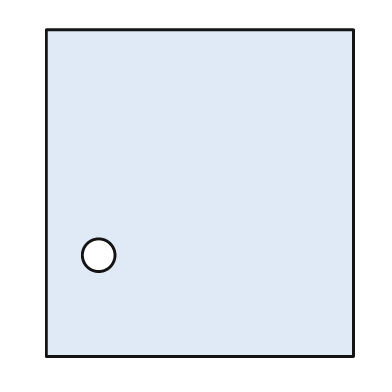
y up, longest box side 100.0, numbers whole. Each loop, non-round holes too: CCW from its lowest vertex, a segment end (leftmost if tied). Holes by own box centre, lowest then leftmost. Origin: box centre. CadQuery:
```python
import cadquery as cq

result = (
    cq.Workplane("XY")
    .moveTo(-47.0, -50.0)
    .lineTo(47.0, -50.0)
    .lineTo(47.0, 50.0)
    .lineTo(-47.0, 50.0)
    .close()
    .moveTo(-31.0, -19.0)
    .circle(5.0)
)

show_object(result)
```